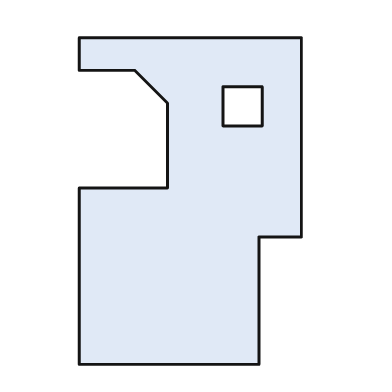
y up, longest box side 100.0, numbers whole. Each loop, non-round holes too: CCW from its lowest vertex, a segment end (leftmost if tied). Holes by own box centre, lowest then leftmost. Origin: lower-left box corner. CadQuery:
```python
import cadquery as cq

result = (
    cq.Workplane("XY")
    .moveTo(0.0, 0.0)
    .lineTo(55.0, 0.0)
    .lineTo(55.0, 39.0)
    .lineTo(68.0, 39.0)
    .lineTo(68.0, 100.0)
    .lineTo(0.0, 100.0)
    .lineTo(0.0, 90.0)
    .lineTo(17.0, 90.0)
    .lineTo(27.0, 80.0)
    .lineTo(27.0, 54.0)
    .lineTo(0.0, 54.0)
    .close()
    .moveTo(44.0, 73.0)
    .lineTo(56.0, 73.0)
    .lineTo(56.0, 85.0)
    .lineTo(44.0, 85.0)
    .close()
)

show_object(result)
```